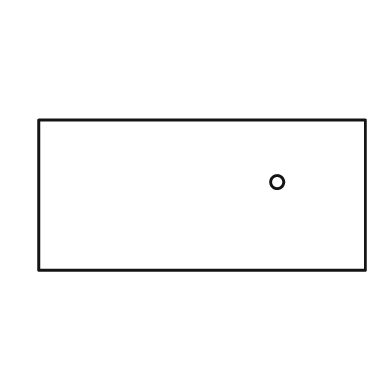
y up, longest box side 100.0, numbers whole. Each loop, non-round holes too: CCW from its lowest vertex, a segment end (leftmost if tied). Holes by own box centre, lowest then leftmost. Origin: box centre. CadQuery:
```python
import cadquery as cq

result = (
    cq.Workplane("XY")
    .moveTo(-50.0, -23.0)
    .lineTo(50.0, -23.0)
    .lineTo(50.0, 23.0)
    .lineTo(-50.0, 23.0)
    .close()
    .moveTo(23.0, 4.0)
    .circle(2.0)
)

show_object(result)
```